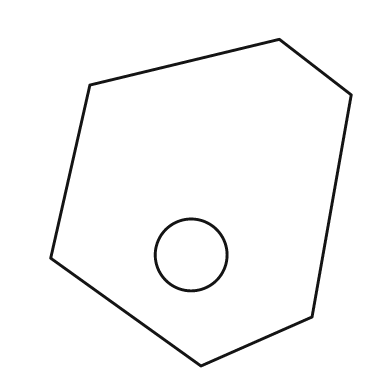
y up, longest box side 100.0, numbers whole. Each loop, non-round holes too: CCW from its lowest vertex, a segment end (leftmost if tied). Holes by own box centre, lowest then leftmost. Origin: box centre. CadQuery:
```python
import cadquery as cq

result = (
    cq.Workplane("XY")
    .moveTo(0.0, -50.0)
    .lineTo(34.0, -35.0)
    .lineTo(46.0, 33.0)
    .lineTo(24.0, 50.0)
    .lineTo(-34.0, 36.0)
    .lineTo(-46.0, -17.0)
    .close()
    .moveTo(-3.0, -16.0)
    .circle(11.0)
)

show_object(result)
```